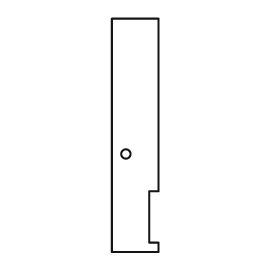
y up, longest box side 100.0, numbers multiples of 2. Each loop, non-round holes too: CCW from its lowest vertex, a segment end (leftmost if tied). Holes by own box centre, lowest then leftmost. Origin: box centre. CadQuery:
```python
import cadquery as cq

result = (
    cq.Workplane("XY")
    .moveTo(-10.0, -50.0)
    .lineTo(10.0, -50.0)
    .lineTo(10.0, -46.0)
    .lineTo(6.0, -46.0)
    .lineTo(6.0, -24.0)
    .lineTo(10.0, -24.0)
    .lineTo(10.0, 50.0)
    .lineTo(-10.0, 50.0)
    .close()
    .moveTo(-4.0, -8.0)
    .circle(2.0)
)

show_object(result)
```